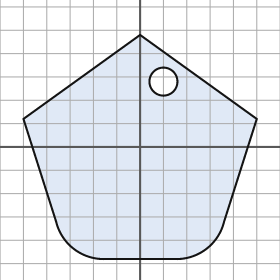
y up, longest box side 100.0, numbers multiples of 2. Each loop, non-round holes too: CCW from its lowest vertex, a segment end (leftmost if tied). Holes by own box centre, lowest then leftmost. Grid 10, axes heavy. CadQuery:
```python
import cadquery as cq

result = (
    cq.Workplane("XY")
    .moveTo(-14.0, -48.0)
    .lineTo(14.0, -48.0)
    .threePointArc((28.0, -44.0), (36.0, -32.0))
    .lineTo(50.0, 12.0)
    .lineTo(0.0, 48.0)
    .lineTo(-50.0, 12.0)
    .lineTo(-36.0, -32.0)
    .threePointArc((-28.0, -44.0), (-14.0, -48.0))
    .close()
    .moveTo(10.0, 28.0)
    .circle(6.0)
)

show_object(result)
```